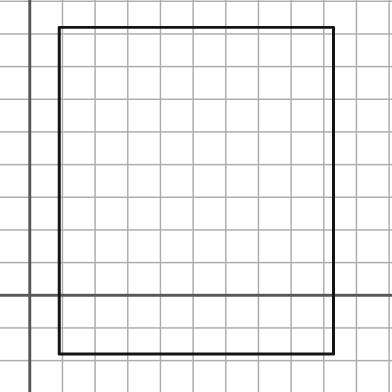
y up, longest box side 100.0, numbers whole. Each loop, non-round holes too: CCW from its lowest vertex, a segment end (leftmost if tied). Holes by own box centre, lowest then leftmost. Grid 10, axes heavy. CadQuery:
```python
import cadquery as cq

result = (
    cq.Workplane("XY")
    .moveTo(9.0, -18.0)
    .lineTo(93.0, -18.0)
    .lineTo(93.0, 82.0)
    .lineTo(9.0, 82.0)
    .close()
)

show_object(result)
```